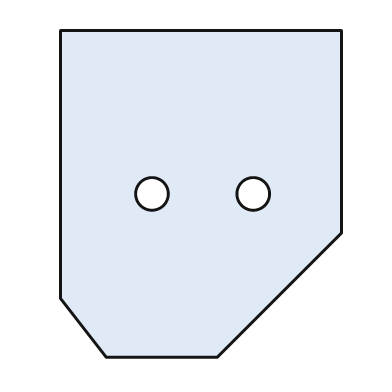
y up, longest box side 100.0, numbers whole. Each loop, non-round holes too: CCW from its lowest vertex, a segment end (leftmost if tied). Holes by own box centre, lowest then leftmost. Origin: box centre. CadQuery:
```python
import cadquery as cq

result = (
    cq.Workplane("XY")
    .moveTo(-29.0, -50.0)
    .lineTo(5.0, -50.0)
    .lineTo(43.0, -12.0)
    .lineTo(43.0, 50.0)
    .lineTo(-43.0, 50.0)
    .lineTo(-43.0, -32.0)
    .close()
    .moveTo(-15.0, 0.0)
    .circle(5.0)
    .moveTo(16.0, 0.0)
    .circle(5.0)
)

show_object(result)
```